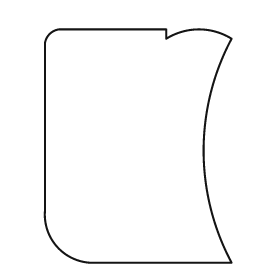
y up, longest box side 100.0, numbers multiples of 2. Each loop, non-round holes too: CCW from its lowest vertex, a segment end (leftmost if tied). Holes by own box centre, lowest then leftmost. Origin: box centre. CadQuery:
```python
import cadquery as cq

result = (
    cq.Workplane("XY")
    .moveTo(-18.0, -50.0)
    .lineTo(40.0, -50.0)
    .threePointArc((28.0, -2.0), (40.0, 46.0))
    .threePointArc((26.0, 50.0), (12.0, 46.0))
    .lineTo(12.0, 50.0)
    .lineTo(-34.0, 50.0)
    .threePointArc((-38.0, 48.0), (-40.0, 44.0))
    .lineTo(-40.0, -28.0)
    .threePointArc((-34.0, -44.0), (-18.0, -50.0))
    .close()
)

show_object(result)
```